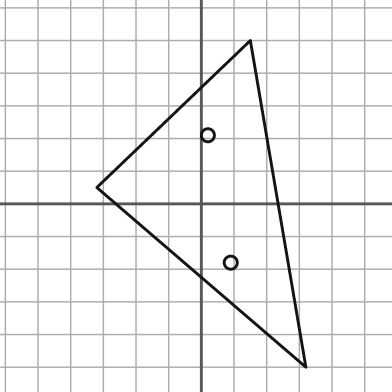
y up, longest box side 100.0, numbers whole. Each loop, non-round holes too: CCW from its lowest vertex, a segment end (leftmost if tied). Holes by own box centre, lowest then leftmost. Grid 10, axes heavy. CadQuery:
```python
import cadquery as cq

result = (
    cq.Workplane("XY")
    .moveTo(32.0, -50.0)
    .lineTo(15.0, 50.0)
    .lineTo(-32.0, 5.0)
    .close()
    .moveTo(9.0, -18.0)
    .circle(2.0)
    .moveTo(2.0, 21.0)
    .circle(2.0)
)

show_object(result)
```